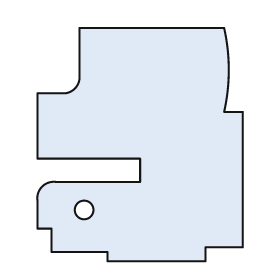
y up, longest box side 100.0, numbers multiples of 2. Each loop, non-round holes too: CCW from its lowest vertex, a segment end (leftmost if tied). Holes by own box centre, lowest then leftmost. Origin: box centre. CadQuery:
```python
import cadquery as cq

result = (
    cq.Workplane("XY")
    .moveTo(-14.0, -50.0)
    .lineTo(28.0, -50.0)
    .lineTo(28.0, -44.0)
    .lineTo(44.0, -44.0)
    .lineTo(44.0, 14.0)
    .lineTo(36.0, 14.0)
    .threePointArc((38.0, 32.0), (36.0, 50.0))
    .lineTo(-26.0, 50.0)
    .lineTo(-26.0, 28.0)
    .threePointArc((-28.0, 24.0), (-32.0, 22.0))
    .lineTo(-44.0, 22.0)
    .lineTo(-44.0, -6.0)
    .lineTo(0.0, -6.0)
    .lineTo(0.0, -16.0)
    .lineTo(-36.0, -16.0)
    .threePointArc((-42.0, -18.0), (-44.0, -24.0))
    .lineTo(-44.0, -36.0)
    .lineTo(-38.0, -36.0)
    .lineTo(-38.0, -46.0)
    .lineTo(-14.0, -46.0)
    .close()
    .moveTo(-24.0, -28.0)
    .circle(4.0)
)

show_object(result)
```